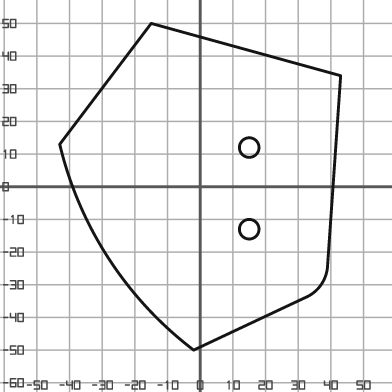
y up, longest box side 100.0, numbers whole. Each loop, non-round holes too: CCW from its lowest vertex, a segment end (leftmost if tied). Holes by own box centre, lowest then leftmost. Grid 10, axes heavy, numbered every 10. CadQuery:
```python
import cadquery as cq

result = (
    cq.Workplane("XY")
    .moveTo(-2.0, -50.0)
    .lineTo(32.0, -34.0)
    .threePointArc((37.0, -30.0), (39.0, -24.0))
    .lineTo(43.0, 34.0)
    .lineTo(-15.0, 50.0)
    .lineTo(-43.0, 13.0)
    .threePointArc((-28.0, -22.0), (-2.0, -50.0))
    .close()
    .moveTo(15.0, -13.0)
    .circle(3.0)
    .moveTo(15.0, 12.0)
    .circle(3.0)
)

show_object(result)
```